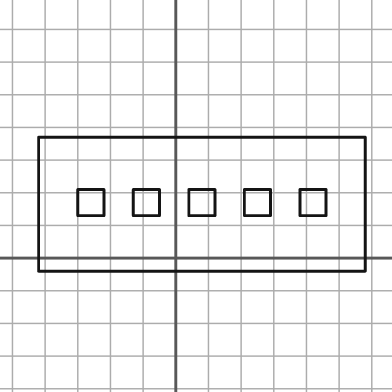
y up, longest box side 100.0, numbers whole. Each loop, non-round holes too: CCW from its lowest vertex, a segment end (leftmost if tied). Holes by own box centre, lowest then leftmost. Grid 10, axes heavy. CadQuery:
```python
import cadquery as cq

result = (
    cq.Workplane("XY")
    .moveTo(-42.0, -4.0)
    .lineTo(58.0, -4.0)
    .lineTo(58.0, 37.0)
    .lineTo(-42.0, 37.0)
    .close()
    .moveTo(-30.0, 13.0)
    .lineTo(-22.0, 13.0)
    .lineTo(-22.0, 21.0)
    .lineTo(-30.0, 21.0)
    .close()
    .moveTo(-13.0, 13.0)
    .lineTo(-5.0, 13.0)
    .lineTo(-5.0, 21.0)
    .lineTo(-13.0, 21.0)
    .close()
    .moveTo(4.0, 13.0)
    .lineTo(12.0, 13.0)
    .lineTo(12.0, 21.0)
    .lineTo(4.0, 21.0)
    .close()
    .moveTo(21.0, 13.0)
    .lineTo(29.0, 13.0)
    .lineTo(29.0, 21.0)
    .lineTo(21.0, 21.0)
    .close()
    .moveTo(38.0, 13.0)
    .lineTo(46.0, 13.0)
    .lineTo(46.0, 21.0)
    .lineTo(38.0, 21.0)
    .close()
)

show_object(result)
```